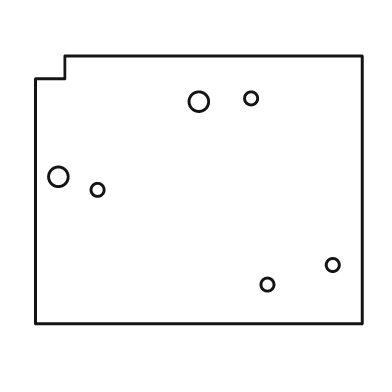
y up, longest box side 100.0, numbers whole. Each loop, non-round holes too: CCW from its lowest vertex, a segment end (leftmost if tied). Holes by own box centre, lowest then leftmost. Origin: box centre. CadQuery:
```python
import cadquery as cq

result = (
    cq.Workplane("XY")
    .moveTo(-50.0, -41.0)
    .lineTo(50.0, -41.0)
    .lineTo(50.0, 41.0)
    .lineTo(-41.0, 41.0)
    .lineTo(-41.0, 34.0)
    .lineTo(-50.0, 34.0)
    .close()
    .moveTo(21.0, -29.0)
    .circle(2.0)
    .moveTo(41.0, -23.0)
    .circle(2.0)
    .moveTo(-31.0, 0.0)
    .circle(2.0)
    .moveTo(-43.0, 4.0)
    .circle(3.0)
    .moveTo(0.0, 27.0)
    .circle(3.0)
    .moveTo(16.0, 28.0)
    .circle(2.0)
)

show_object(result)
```